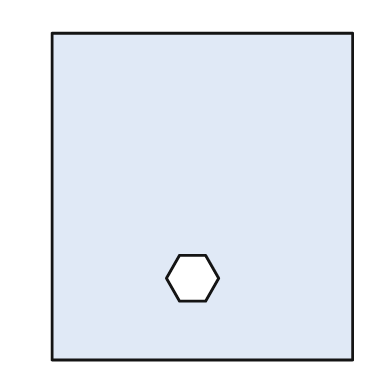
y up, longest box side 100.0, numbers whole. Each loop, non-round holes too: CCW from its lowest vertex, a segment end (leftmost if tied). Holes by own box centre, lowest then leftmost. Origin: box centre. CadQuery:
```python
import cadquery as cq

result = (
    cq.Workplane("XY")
    .moveTo(-46.0, -50.0)
    .lineTo(46.0, -50.0)
    .lineTo(46.0, 50.0)
    .lineTo(-46.0, 50.0)
    .close()
    .moveTo(-7.0, -32.0)
    .lineTo(1.0, -32.0)
    .lineTo(5.0, -25.0)
    .lineTo(1.0, -18.0)
    .lineTo(-7.0, -18.0)
    .lineTo(-11.0, -25.0)
    .close()
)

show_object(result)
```